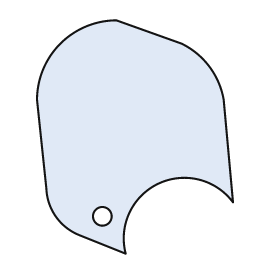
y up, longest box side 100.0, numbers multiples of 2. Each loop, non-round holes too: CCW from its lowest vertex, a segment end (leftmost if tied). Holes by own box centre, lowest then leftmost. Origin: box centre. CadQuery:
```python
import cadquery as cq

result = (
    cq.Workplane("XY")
    .moveTo(-4.0, -50.0)
    .threePointArc((10.0, -20.0), (42.0, -28.0))
    .lineTo(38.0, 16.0)
    .threePointArc((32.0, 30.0), (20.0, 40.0))
    .lineTo(-8.0, 50.0)
    .threePointArc((-32.0, 40.0), (-42.0, 16.0))
    .lineTo(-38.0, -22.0)
    .threePointArc((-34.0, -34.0), (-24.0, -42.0))
    .close()
    .moveTo(-14.0, -34.0)
    .circle(4.0)
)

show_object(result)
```